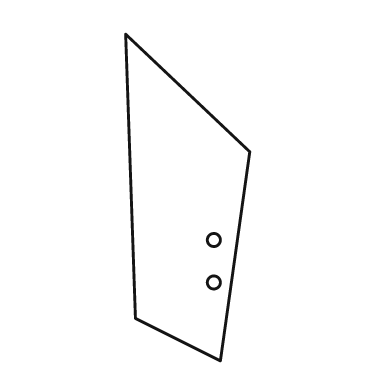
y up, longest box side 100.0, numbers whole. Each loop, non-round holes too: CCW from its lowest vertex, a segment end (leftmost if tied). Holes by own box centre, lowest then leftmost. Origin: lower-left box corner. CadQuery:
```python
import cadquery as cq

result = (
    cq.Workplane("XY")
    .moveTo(29.0, 0.0)
    .lineTo(38.0, 64.0)
    .lineTo(0.0, 100.0)
    .lineTo(3.0, 13.0)
    .close()
    .moveTo(27.0, 24.0)
    .circle(2.0)
    .moveTo(27.0, 37.0)
    .circle(2.0)
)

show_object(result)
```